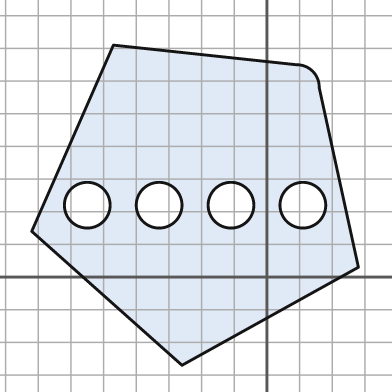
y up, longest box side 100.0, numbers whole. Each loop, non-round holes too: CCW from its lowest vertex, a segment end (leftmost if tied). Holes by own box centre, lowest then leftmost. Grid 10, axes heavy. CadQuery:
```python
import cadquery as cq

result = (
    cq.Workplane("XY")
    .moveTo(-26.0, -27.0)
    .lineTo(28.0, 3.0)
    .lineTo(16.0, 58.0)
    .threePointArc((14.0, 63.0), (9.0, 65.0))
    .lineTo(-47.0, 71.0)
    .lineTo(-72.0, 14.0)
    .close()
    .moveTo(-55.0, 22.0)
    .circle(7.0)
    .moveTo(-33.0, 22.0)
    .circle(7.0)
    .moveTo(-11.0, 22.0)
    .circle(7.0)
    .moveTo(11.0, 22.0)
    .circle(7.0)
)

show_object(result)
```